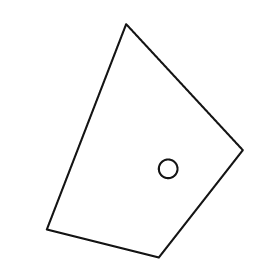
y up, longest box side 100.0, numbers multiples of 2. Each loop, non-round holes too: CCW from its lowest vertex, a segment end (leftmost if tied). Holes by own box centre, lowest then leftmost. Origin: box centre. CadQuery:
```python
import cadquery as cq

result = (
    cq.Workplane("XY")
    .moveTo(6.0, -50.0)
    .lineTo(42.0, -4.0)
    .lineTo(-8.0, 50.0)
    .lineTo(-42.0, -38.0)
    .close()
    .moveTo(10.0, -12.0)
    .circle(4.0)
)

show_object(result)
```